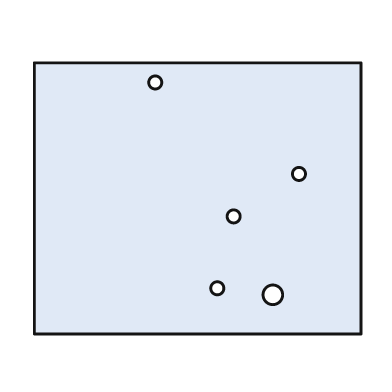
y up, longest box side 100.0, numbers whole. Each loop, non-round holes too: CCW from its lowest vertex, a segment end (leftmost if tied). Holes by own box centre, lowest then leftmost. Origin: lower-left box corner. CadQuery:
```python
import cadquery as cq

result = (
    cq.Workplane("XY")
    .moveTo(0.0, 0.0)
    .lineTo(100.0, 0.0)
    .lineTo(100.0, 83.0)
    .lineTo(0.0, 83.0)
    .close()
    .moveTo(73.0, 12.0)
    .circle(3.0)
    .moveTo(56.0, 14.0)
    .circle(2.0)
    .moveTo(61.0, 36.0)
    .circle(2.0)
    .moveTo(81.0, 49.0)
    .circle(2.0)
    .moveTo(37.0, 77.0)
    .circle(2.0)
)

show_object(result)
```